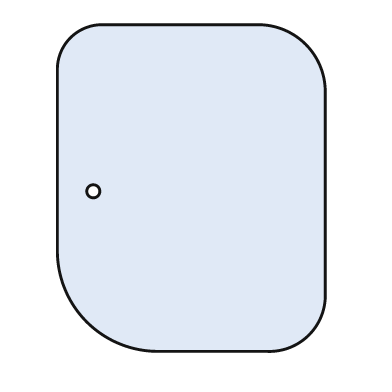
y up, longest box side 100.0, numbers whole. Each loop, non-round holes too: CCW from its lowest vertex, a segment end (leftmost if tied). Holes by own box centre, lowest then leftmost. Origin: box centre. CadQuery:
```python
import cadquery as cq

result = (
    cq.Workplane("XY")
    .moveTo(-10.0, -50.0)
    .lineTo(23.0, -50.0)
    .threePointArc((36.0, -45.0), (41.0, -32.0))
    .lineTo(41.0, 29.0)
    .threePointArc((35.0, 44.0), (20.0, 50.0))
    .lineTo(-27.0, 50.0)
    .threePointArc((-37.0, 46.0), (-41.0, 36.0))
    .lineTo(-41.0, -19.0)
    .threePointArc((-32.0, -41.0), (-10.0, -50.0))
    .close()
    .moveTo(-30.0, -1.0)
    .circle(2.0)
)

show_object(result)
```